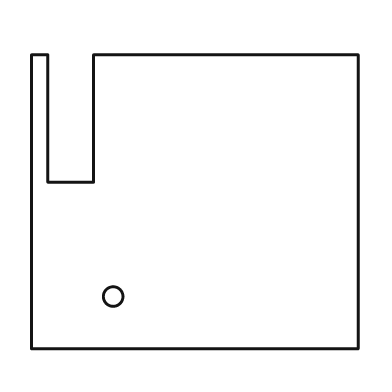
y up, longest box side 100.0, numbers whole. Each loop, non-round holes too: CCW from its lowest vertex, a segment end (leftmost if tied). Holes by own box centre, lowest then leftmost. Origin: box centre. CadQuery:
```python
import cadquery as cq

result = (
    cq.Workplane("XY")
    .moveTo(-50.0, -45.0)
    .lineTo(50.0, -45.0)
    .lineTo(50.0, 45.0)
    .lineTo(-31.0, 45.0)
    .lineTo(-31.0, 6.0)
    .lineTo(-45.0, 6.0)
    .lineTo(-45.0, 45.0)
    .lineTo(-50.0, 45.0)
    .close()
    .moveTo(-25.0, -29.0)
    .circle(3.0)
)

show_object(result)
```